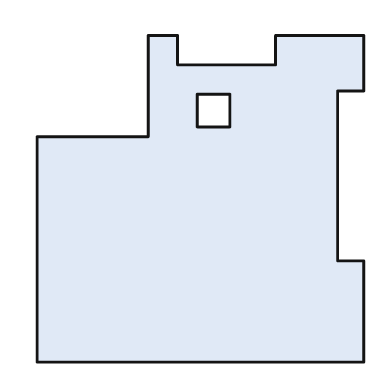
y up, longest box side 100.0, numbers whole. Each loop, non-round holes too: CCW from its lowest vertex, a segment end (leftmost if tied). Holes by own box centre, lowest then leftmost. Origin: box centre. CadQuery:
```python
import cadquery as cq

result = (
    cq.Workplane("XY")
    .moveTo(-50.0, -50.0)
    .lineTo(50.0, -50.0)
    .lineTo(50.0, -19.0)
    .lineTo(42.0, -19.0)
    .lineTo(42.0, 33.0)
    .lineTo(50.0, 33.0)
    .lineTo(50.0, 50.0)
    .lineTo(23.0, 50.0)
    .lineTo(23.0, 41.0)
    .lineTo(-7.0, 41.0)
    .lineTo(-7.0, 50.0)
    .lineTo(-16.0, 50.0)
    .lineTo(-16.0, 19.0)
    .lineTo(-50.0, 19.0)
    .close()
    .moveTo(-1.0, 22.0)
    .lineTo(9.0, 22.0)
    .lineTo(9.0, 32.0)
    .lineTo(-1.0, 32.0)
    .close()
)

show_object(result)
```